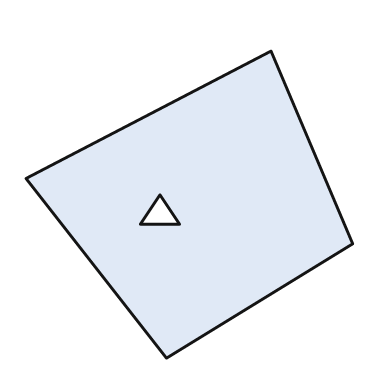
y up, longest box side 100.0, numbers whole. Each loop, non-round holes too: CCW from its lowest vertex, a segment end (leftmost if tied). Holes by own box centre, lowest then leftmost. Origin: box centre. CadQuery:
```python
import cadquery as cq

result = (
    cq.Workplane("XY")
    .moveTo(-7.0, -47.0)
    .lineTo(50.0, -12.0)
    .lineTo(25.0, 47.0)
    .lineTo(-50.0, 8.0)
    .close()
    .moveTo(-15.0, -6.0)
    .lineTo(-3.0, -6.0)
    .lineTo(-9.0, 3.0)
    .close()
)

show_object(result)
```